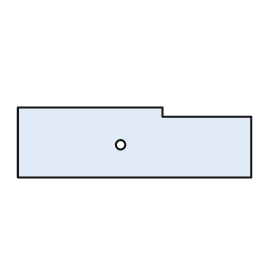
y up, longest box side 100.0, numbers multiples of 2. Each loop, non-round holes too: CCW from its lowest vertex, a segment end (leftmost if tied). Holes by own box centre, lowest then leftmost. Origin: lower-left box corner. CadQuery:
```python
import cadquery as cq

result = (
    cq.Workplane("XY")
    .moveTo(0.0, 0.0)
    .lineTo(100.0, 0.0)
    .lineTo(100.0, 26.0)
    .lineTo(62.0, 26.0)
    .lineTo(62.0, 30.0)
    .lineTo(0.0, 30.0)
    .close()
    .moveTo(44.0, 14.0)
    .circle(2.0)
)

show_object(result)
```